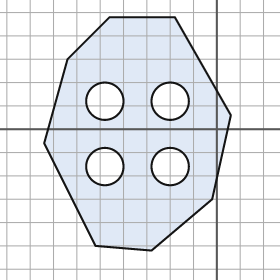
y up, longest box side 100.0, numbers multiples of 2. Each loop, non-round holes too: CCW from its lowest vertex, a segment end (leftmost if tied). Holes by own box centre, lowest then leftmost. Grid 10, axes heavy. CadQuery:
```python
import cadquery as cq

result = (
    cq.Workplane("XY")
    .moveTo(-28.0, -52.0)
    .lineTo(-2.0, -30.0)
    .lineTo(6.0, 6.0)
    .lineTo(-18.0, 48.0)
    .lineTo(-46.0, 48.0)
    .lineTo(-64.0, 30.0)
    .lineTo(-74.0, -6.0)
    .lineTo(-52.0, -50.0)
    .close()
    .moveTo(-48.0, -16.0)
    .circle(8.0)
    .moveTo(-20.0, -16.0)
    .circle(8.0)
    .moveTo(-48.0, 12.0)
    .circle(8.0)
    .moveTo(-20.0, 12.0)
    .circle(8.0)
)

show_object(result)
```